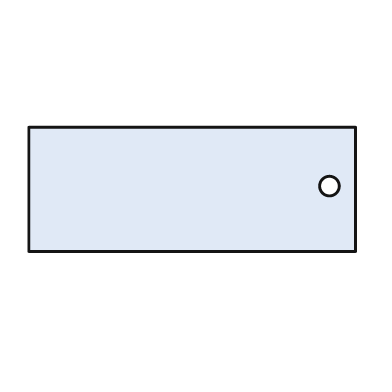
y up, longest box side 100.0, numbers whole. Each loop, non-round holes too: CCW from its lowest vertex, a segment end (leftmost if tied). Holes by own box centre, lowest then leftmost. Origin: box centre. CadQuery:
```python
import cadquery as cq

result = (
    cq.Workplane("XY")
    .moveTo(-50.0, -19.0)
    .lineTo(50.0, -19.0)
    .lineTo(50.0, 19.0)
    .lineTo(-50.0, 19.0)
    .close()
    .moveTo(42.0, 1.0)
    .circle(3.0)
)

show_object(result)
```